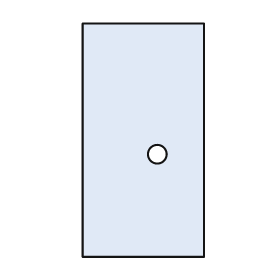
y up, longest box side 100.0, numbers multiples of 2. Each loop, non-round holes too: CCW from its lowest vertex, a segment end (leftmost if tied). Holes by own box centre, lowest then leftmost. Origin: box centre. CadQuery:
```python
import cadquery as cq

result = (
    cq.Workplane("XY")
    .moveTo(-26.0, -50.0)
    .lineTo(26.0, -50.0)
    .lineTo(26.0, 50.0)
    .lineTo(-26.0, 50.0)
    .close()
    .moveTo(6.0, -6.0)
    .circle(4.0)
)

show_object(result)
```